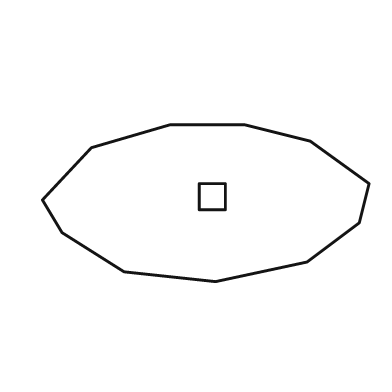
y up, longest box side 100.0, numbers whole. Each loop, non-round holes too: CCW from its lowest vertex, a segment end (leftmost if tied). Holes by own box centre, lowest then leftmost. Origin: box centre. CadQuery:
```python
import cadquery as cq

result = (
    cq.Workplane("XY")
    .moveTo(3.0, -24.0)
    .lineTo(31.0, -18.0)
    .lineTo(47.0, -6.0)
    .lineTo(50.0, 6.0)
    .lineTo(32.0, 19.0)
    .lineTo(12.0, 24.0)
    .lineTo(-11.0, 24.0)
    .lineTo(-35.0, 17.0)
    .lineTo(-50.0, 1.0)
    .lineTo(-44.0, -9.0)
    .lineTo(-25.0, -21.0)
    .close()
    .moveTo(-2.0, -2.0)
    .lineTo(6.0, -2.0)
    .lineTo(6.0, 6.0)
    .lineTo(-2.0, 6.0)
    .close()
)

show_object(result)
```